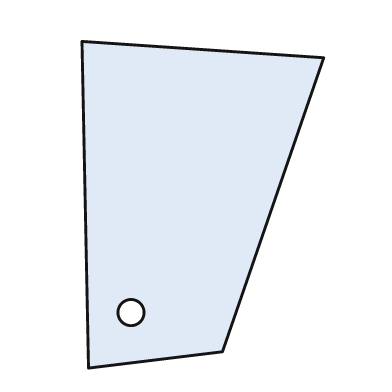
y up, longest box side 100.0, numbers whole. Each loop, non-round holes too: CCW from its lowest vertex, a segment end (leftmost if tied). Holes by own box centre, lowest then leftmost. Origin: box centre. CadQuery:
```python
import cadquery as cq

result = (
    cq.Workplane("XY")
    .moveTo(-35.0, -50.0)
    .lineTo(6.0, -45.0)
    .lineTo(37.0, 45.0)
    .lineTo(-37.0, 50.0)
    .close()
    .moveTo(-22.0, -33.0)
    .circle(4.0)
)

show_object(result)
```